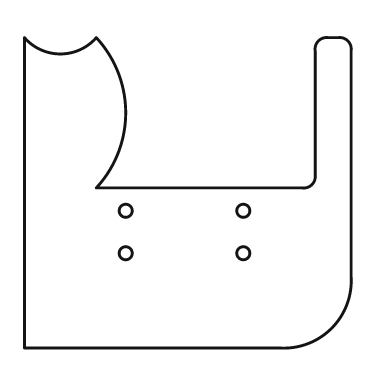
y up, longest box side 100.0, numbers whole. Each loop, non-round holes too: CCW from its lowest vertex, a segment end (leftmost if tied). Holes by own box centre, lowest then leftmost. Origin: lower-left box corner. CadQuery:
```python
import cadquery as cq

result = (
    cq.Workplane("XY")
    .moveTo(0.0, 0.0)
    .lineTo(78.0, 0.0)
    .threePointArc((94.0, 6.0), (100.0, 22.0))
    .lineTo(100.0, 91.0)
    .threePointArc((99.0, 94.0), (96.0, 95.0))
    .lineTo(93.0, 95.0)
    .threePointArc((90.0, 94.0), (89.0, 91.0))
    .lineTo(89.0, 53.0)
    .threePointArc((88.0, 50.0), (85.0, 49.0))
    .lineTo(22.0, 49.0)
    .threePointArc((31.0, 72.0), (22.0, 95.0))
    .threePointArc((11.0, 90.0), (0.0, 95.0))
    .close()
    .moveTo(31.0, 29.0)
    .circle(2.0)
    .moveTo(67.0, 29.0)
    .circle(2.0)
    .moveTo(31.0, 42.0)
    .circle(2.0)
    .moveTo(67.0, 42.0)
    .circle(2.0)
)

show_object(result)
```